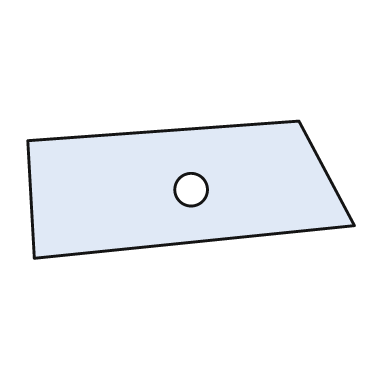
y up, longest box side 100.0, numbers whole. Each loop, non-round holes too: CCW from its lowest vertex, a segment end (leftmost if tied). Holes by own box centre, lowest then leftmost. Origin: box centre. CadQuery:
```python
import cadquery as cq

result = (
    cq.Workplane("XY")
    .moveTo(-48.0, -21.0)
    .lineTo(50.0, -11.0)
    .lineTo(33.0, 21.0)
    .lineTo(-50.0, 15.0)
    .close()
    .moveTo(0.0, 0.0)
    .circle(5.0)
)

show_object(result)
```